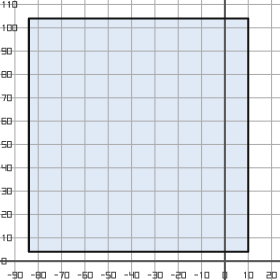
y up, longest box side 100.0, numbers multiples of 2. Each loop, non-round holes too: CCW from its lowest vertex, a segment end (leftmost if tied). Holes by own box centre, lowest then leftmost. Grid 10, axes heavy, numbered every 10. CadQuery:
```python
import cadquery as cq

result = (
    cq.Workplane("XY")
    .moveTo(-84.0, 4.0)
    .lineTo(10.0, 4.0)
    .lineTo(10.0, 104.0)
    .lineTo(-84.0, 104.0)
    .close()
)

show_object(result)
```